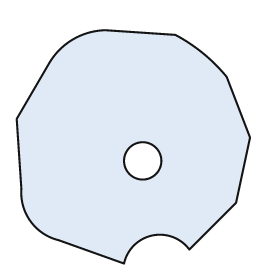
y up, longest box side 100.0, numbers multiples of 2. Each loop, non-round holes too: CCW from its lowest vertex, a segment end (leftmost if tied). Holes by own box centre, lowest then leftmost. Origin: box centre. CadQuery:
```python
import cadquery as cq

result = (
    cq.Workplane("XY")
    .moveTo(-4.0, -50.0)
    .threePointArc((8.0, -38.0), (24.0, -44.0))
    .lineTo(44.0, -24.0)
    .lineTo(50.0, 4.0)
    .lineTo(40.0, 30.0)
    .threePointArc((30.0, 40.0), (18.0, 48.0))
    .lineTo(-12.0, 50.0)
    .threePointArc((-26.0, 46.0), (-36.0, 36.0))
    .lineTo(-50.0, 12.0)
    .lineTo(-48.0, -18.0)
    .threePointArc((-44.0, -32.0), (-32.0, -40.0))
    .close()
    .moveTo(4.0, -6.0)
    .circle(8.0)
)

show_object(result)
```